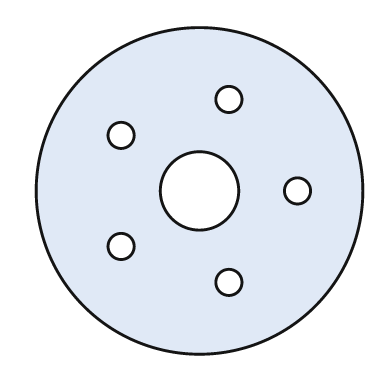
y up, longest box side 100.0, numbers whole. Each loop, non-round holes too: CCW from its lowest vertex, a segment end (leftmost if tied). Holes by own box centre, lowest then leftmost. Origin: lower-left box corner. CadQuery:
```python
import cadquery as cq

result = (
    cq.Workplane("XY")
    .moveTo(50.0, 50.0)
    .circle(50.0)
    .moveTo(59.0, 22.0)
    .circle(4.0)
    .moveTo(26.0, 33.0)
    .circle(4.0)
    .moveTo(50.0, 50.0)
    .circle(12.0)
    .moveTo(80.0, 50.0)
    .circle(4.0)
    .moveTo(26.0, 67.0)
    .circle(4.0)
    .moveTo(59.0, 78.0)
    .circle(4.0)
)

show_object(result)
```